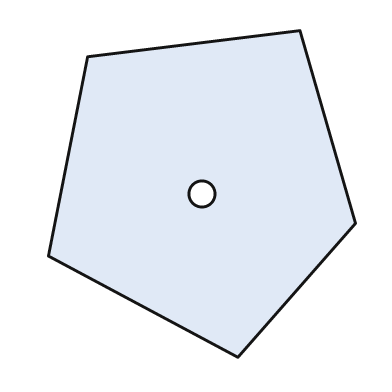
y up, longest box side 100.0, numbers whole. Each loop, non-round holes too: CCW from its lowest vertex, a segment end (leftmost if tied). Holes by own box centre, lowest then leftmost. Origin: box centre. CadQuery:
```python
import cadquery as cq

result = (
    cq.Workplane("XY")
    .moveTo(11.0, -50.0)
    .lineTo(47.0, -9.0)
    .lineTo(30.0, 50.0)
    .lineTo(-35.0, 42.0)
    .lineTo(-47.0, -19.0)
    .close()
    .moveTo(0.0, 0.0)
    .circle(4.0)
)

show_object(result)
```